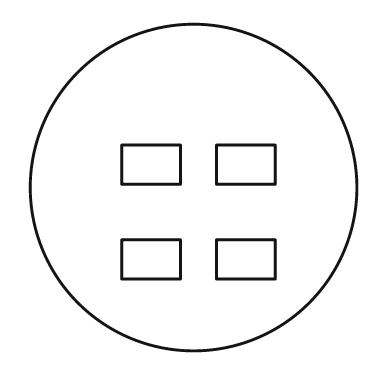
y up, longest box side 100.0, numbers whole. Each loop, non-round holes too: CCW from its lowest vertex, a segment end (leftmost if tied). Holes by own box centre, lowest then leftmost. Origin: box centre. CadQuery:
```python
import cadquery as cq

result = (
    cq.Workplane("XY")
    .moveTo(0.0, 0.0)
    .circle(50.0)
    .moveTo(-22.0, -28.0)
    .lineTo(-4.0, -28.0)
    .lineTo(-4.0, -16.0)
    .lineTo(-22.0, -16.0)
    .close()
    .moveTo(7.0, -28.0)
    .lineTo(25.0, -28.0)
    .lineTo(25.0, -16.0)
    .lineTo(7.0, -16.0)
    .close()
    .moveTo(-22.0, 1.0)
    .lineTo(-4.0, 1.0)
    .lineTo(-4.0, 13.0)
    .lineTo(-22.0, 13.0)
    .close()
    .moveTo(7.0, 1.0)
    .lineTo(25.0, 1.0)
    .lineTo(25.0, 13.0)
    .lineTo(7.0, 13.0)
    .close()
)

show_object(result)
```